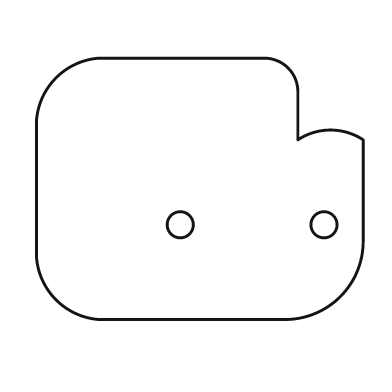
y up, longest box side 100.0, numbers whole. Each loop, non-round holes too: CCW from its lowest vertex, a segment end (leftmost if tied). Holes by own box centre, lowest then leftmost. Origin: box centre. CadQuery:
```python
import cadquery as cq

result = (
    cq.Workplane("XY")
    .moveTo(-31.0, -40.0)
    .lineTo(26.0, -40.0)
    .threePointArc((43.0, -33.0), (50.0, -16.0))
    .lineTo(50.0, 15.0)
    .threePointArc((40.0, 18.0), (30.0, 15.0))
    .lineTo(30.0, 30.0)
    .threePointArc((27.0, 37.0), (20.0, 40.0))
    .lineTo(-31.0, 40.0)
    .threePointArc((-44.0, 34.0), (-50.0, 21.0))
    .lineTo(-50.0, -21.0)
    .threePointArc((-44.0, -34.0), (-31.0, -40.0))
    .close()
    .moveTo(-6.0, -11.0)
    .circle(4.0)
    .moveTo(38.0, -11.0)
    .circle(4.0)
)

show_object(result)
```